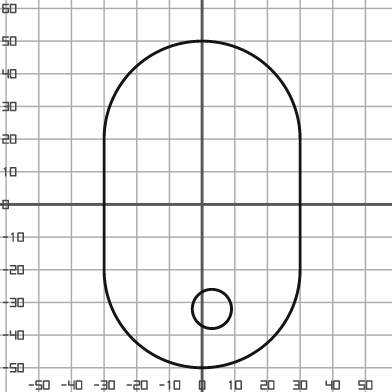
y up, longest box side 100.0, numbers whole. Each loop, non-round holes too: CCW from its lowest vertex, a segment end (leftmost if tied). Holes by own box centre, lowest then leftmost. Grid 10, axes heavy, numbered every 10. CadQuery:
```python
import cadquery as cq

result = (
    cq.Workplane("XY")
    .moveTo(-30.0, -20.0)
    .threePointArc((0.0, -50.0), (30.0, -20.0))
    .lineTo(30.0, 20.0)
    .threePointArc((0.0, 50.0), (-30.0, 20.0))
    .close()
    .moveTo(3.0, -32.0)
    .circle(6.0)
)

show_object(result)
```